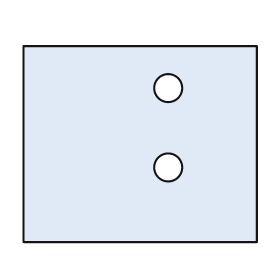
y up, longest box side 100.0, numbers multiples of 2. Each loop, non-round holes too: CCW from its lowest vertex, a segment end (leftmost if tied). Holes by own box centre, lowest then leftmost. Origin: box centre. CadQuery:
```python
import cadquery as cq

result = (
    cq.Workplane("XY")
    .moveTo(-50.0, -42.0)
    .lineTo(50.0, -42.0)
    .lineTo(50.0, 42.0)
    .lineTo(-50.0, 42.0)
    .close()
    .moveTo(12.0, -10.0)
    .circle(6.0)
    .moveTo(12.0, 24.0)
    .circle(6.0)
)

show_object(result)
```